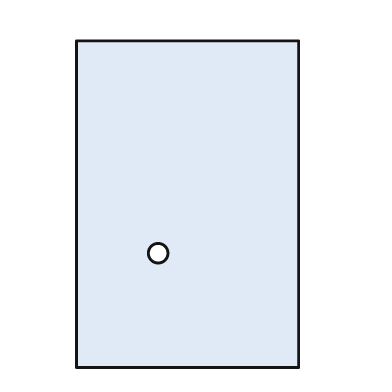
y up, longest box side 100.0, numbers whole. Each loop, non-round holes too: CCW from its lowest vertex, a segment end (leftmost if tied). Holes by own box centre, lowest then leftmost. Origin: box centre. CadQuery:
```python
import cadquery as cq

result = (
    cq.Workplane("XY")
    .moveTo(-34.0, -50.0)
    .lineTo(34.0, -50.0)
    .lineTo(34.0, 50.0)
    .lineTo(-34.0, 50.0)
    .close()
    .moveTo(-9.0, -15.0)
    .circle(3.0)
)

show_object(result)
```